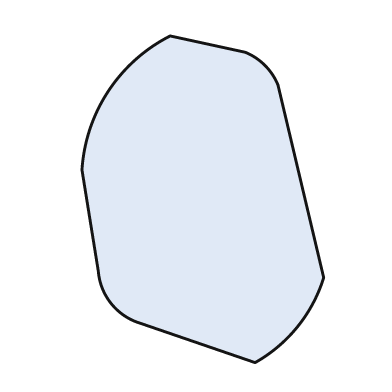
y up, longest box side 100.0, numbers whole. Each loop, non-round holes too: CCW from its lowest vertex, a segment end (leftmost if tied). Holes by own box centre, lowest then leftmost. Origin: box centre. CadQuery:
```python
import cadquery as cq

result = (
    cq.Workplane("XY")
    .moveTo(16.0, -50.0)
    .threePointArc((29.0, -39.0), (37.0, -24.0))
    .lineTo(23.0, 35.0)
    .threePointArc((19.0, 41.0), (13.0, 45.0))
    .lineTo(-10.0, 50.0)
    .threePointArc((-29.0, 33.0), (-37.0, 9.0))
    .lineTo(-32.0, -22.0)
    .threePointArc((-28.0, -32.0), (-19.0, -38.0))
    .close()
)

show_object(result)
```